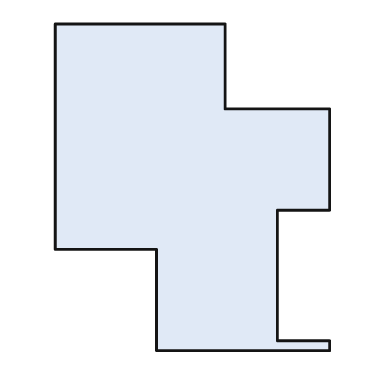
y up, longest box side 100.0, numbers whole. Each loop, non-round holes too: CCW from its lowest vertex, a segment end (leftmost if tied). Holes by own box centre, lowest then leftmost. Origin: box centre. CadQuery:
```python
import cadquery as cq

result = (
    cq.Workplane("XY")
    .moveTo(-11.0, -50.0)
    .lineTo(42.0, -50.0)
    .lineTo(42.0, -47.0)
    .lineTo(26.0, -47.0)
    .lineTo(26.0, -7.0)
    .lineTo(42.0, -7.0)
    .lineTo(42.0, 24.0)
    .lineTo(10.0, 24.0)
    .lineTo(10.0, 50.0)
    .lineTo(-42.0, 50.0)
    .lineTo(-42.0, -19.0)
    .lineTo(-11.0, -19.0)
    .close()
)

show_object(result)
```